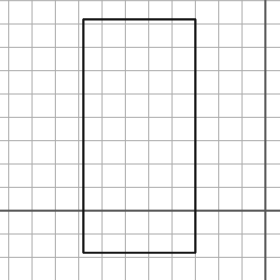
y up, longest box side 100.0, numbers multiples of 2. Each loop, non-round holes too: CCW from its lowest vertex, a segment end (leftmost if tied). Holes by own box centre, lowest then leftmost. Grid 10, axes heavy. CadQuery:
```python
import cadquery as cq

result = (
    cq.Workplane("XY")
    .moveTo(-78.0, -18.0)
    .lineTo(-30.0, -18.0)
    .lineTo(-30.0, 82.0)
    .lineTo(-78.0, 82.0)
    .close()
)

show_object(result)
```